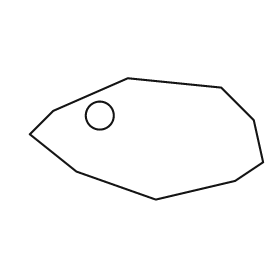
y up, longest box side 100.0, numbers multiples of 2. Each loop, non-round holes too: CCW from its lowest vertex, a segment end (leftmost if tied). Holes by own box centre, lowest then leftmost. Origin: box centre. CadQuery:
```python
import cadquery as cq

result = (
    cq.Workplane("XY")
    .moveTo(4.0, -26.0)
    .lineTo(38.0, -18.0)
    .lineTo(50.0, -10.0)
    .lineTo(46.0, 8.0)
    .lineTo(32.0, 22.0)
    .lineTo(-8.0, 26.0)
    .lineTo(-40.0, 12.0)
    .lineTo(-50.0, 2.0)
    .lineTo(-30.0, -14.0)
    .close()
    .moveTo(-20.0, 10.0)
    .circle(6.0)
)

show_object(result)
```